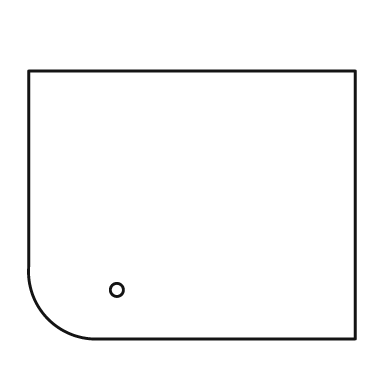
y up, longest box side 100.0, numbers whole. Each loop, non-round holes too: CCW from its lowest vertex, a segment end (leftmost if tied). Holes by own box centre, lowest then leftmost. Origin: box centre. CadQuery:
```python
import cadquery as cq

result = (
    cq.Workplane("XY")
    .moveTo(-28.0, -41.0)
    .lineTo(50.0, -41.0)
    .lineTo(50.0, 41.0)
    .lineTo(-50.0, 41.0)
    .lineTo(-50.0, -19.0)
    .threePointArc((-44.0, -35.0), (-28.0, -41.0))
    .close()
    .moveTo(-23.0, -26.0)
    .circle(2.0)
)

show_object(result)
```